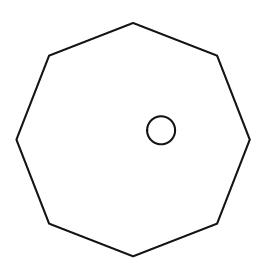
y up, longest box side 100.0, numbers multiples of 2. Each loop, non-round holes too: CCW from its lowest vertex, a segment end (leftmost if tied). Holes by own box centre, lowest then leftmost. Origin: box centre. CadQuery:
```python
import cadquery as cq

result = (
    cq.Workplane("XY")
    .moveTo(0.0, -50.0)
    .lineTo(36.0, -36.0)
    .lineTo(50.0, 0.0)
    .lineTo(36.0, 36.0)
    .lineTo(0.0, 50.0)
    .lineTo(-36.0, 36.0)
    .lineTo(-50.0, 0.0)
    .lineTo(-36.0, -36.0)
    .close()
    .moveTo(12.0, 4.0)
    .circle(6.0)
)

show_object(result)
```